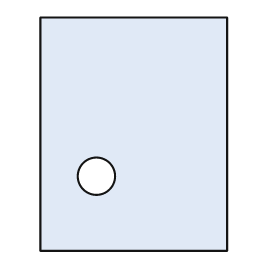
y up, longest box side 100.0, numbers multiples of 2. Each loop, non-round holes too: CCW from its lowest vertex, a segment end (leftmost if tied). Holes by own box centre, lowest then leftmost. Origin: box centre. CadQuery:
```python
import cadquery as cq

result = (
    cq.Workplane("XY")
    .moveTo(-40.0, -50.0)
    .lineTo(40.0, -50.0)
    .lineTo(40.0, 50.0)
    .lineTo(-40.0, 50.0)
    .close()
    .moveTo(-16.0, -18.0)
    .circle(8.0)
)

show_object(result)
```